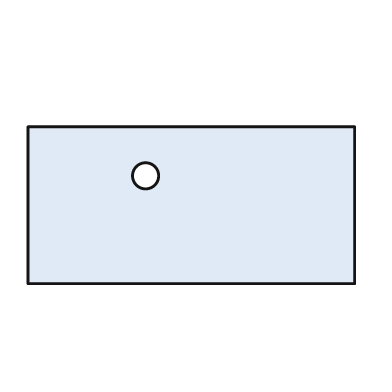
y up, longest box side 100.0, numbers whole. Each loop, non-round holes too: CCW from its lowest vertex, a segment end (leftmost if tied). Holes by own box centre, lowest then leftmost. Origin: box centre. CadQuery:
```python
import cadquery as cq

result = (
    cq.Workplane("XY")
    .moveTo(-50.0, -24.0)
    .lineTo(50.0, -24.0)
    .lineTo(50.0, 24.0)
    .lineTo(-50.0, 24.0)
    .close()
    .moveTo(-14.0, 9.0)
    .circle(4.0)
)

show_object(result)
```